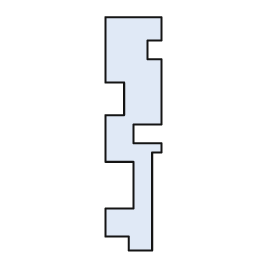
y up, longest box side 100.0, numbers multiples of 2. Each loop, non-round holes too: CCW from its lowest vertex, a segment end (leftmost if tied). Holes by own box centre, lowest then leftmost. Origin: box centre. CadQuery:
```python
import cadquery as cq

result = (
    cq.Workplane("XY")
    .moveTo(-2.0, -50.0)
    .lineTo(8.0, -50.0)
    .lineTo(8.0, -8.0)
    .lineTo(12.0, -8.0)
    .lineTo(12.0, -4.0)
    .lineTo(0.0, -4.0)
    .lineTo(0.0, 4.0)
    .lineTo(12.0, 4.0)
    .lineTo(12.0, 32.0)
    .lineTo(6.0, 32.0)
    .lineTo(6.0, 40.0)
    .lineTo(12.0, 40.0)
    .lineTo(12.0, 50.0)
    .lineTo(-12.0, 50.0)
    .lineTo(-12.0, 22.0)
    .lineTo(-4.0, 22.0)
    .lineTo(-4.0, 8.0)
    .lineTo(-12.0, 8.0)
    .lineTo(-12.0, -12.0)
    .lineTo(0.0, -12.0)
    .lineTo(0.0, -32.0)
    .lineTo(-12.0, -32.0)
    .lineTo(-12.0, -44.0)
    .lineTo(-2.0, -44.0)
    .close()
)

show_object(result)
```